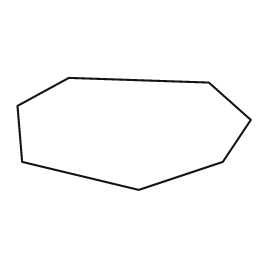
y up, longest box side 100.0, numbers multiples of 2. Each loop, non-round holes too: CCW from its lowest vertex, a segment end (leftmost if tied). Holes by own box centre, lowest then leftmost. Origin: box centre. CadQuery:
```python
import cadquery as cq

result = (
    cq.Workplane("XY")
    .moveTo(2.0, -24.0)
    .lineTo(38.0, -12.0)
    .lineTo(50.0, 6.0)
    .lineTo(32.0, 22.0)
    .lineTo(-28.0, 24.0)
    .lineTo(-50.0, 12.0)
    .lineTo(-48.0, -12.0)
    .close()
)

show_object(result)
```